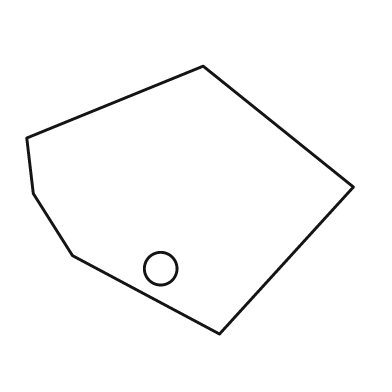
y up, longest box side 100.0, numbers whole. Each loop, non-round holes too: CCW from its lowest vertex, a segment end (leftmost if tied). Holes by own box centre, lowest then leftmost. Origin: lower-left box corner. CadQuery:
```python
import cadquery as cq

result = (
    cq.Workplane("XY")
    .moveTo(59.0, 0.0)
    .lineTo(100.0, 45.0)
    .lineTo(54.0, 82.0)
    .lineTo(0.0, 60.0)
    .lineTo(2.0, 43.0)
    .lineTo(14.0, 24.0)
    .close()
    .moveTo(41.0, 20.0)
    .circle(5.0)
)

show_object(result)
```